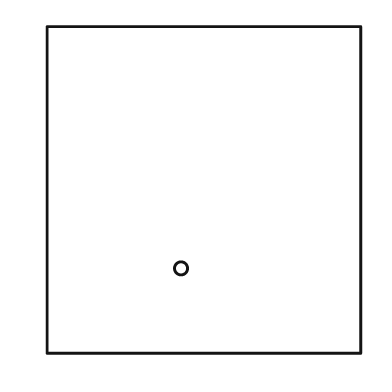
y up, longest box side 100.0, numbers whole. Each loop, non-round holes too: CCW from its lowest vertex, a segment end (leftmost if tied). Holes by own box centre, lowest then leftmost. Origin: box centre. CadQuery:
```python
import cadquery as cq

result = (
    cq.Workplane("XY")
    .moveTo(-48.0, -50.0)
    .lineTo(48.0, -50.0)
    .lineTo(48.0, 50.0)
    .lineTo(-48.0, 50.0)
    .close()
    .moveTo(-7.0, -24.0)
    .circle(2.0)
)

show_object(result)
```